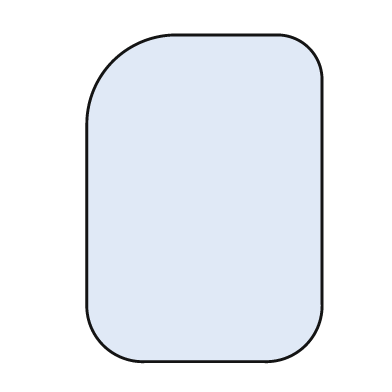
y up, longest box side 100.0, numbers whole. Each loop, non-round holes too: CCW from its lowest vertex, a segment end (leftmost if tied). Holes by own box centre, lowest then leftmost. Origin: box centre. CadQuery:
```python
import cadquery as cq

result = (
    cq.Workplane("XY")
    .moveTo(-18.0, -50.0)
    .lineTo(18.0, -50.0)
    .threePointArc((31.0, -45.0), (36.0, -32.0))
    .lineTo(36.0, 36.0)
    .threePointArc((32.0, 46.0), (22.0, 50.0))
    .lineTo(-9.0, 50.0)
    .threePointArc((-28.0, 42.0), (-36.0, 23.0))
    .lineTo(-36.0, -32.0)
    .threePointArc((-31.0, -45.0), (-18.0, -50.0))
    .close()
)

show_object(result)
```